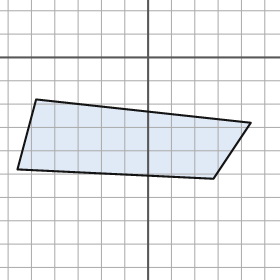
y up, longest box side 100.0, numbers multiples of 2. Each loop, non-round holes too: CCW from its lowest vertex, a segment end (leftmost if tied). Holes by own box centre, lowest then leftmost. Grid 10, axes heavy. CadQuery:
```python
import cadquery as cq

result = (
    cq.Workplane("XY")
    .moveTo(28.0, -52.0)
    .lineTo(44.0, -28.0)
    .lineTo(-48.0, -18.0)
    .lineTo(-56.0, -48.0)
    .close()
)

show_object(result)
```